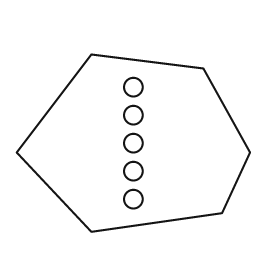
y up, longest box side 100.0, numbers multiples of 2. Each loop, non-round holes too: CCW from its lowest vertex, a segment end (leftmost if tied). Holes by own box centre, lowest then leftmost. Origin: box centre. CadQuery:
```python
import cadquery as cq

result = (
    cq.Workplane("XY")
    .moveTo(-18.0, -38.0)
    .lineTo(38.0, -30.0)
    .lineTo(50.0, -4.0)
    .lineTo(30.0, 32.0)
    .lineTo(-18.0, 38.0)
    .lineTo(-50.0, -4.0)
    .close()
    .moveTo(0.0, -24.0)
    .circle(4.0)
    .moveTo(0.0, -12.0)
    .circle(4.0)
    .moveTo(0.0, 0.0)
    .circle(4.0)
    .moveTo(0.0, 12.0)
    .circle(4.0)
    .moveTo(0.0, 24.0)
    .circle(4.0)
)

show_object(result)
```